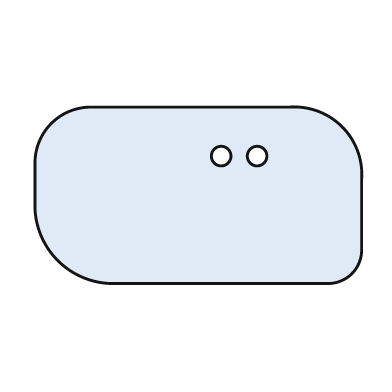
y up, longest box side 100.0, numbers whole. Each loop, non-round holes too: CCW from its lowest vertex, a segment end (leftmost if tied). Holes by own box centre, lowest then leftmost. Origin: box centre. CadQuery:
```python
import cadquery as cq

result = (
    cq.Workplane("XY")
    .moveTo(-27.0, -27.0)
    .lineTo(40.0, -27.0)
    .threePointArc((47.0, -24.0), (50.0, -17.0))
    .lineTo(50.0, 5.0)
    .threePointArc((44.0, 21.0), (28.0, 27.0))
    .lineTo(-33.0, 27.0)
    .threePointArc((-45.0, 22.0), (-50.0, 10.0))
    .lineTo(-50.0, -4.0)
    .threePointArc((-43.0, -20.0), (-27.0, -27.0))
    .close()
    .moveTo(7.0, 12.0)
    .circle(3.0)
    .moveTo(18.0, 12.0)
    .circle(3.0)
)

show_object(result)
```